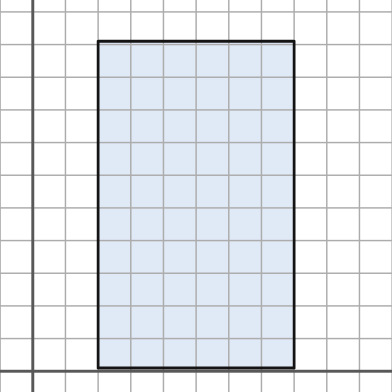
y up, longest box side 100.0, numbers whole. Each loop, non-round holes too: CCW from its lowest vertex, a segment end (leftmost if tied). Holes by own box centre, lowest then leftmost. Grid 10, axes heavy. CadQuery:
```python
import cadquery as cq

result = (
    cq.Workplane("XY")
    .moveTo(20.0, 1.0)
    .lineTo(80.0, 1.0)
    .lineTo(80.0, 101.0)
    .lineTo(20.0, 101.0)
    .close()
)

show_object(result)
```